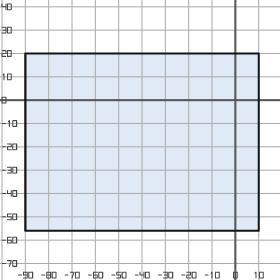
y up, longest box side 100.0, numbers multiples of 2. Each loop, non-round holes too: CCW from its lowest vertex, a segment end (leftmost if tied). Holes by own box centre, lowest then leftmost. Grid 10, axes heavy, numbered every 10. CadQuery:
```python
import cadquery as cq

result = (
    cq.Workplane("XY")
    .moveTo(-90.0, -56.0)
    .lineTo(10.0, -56.0)
    .lineTo(10.0, 20.0)
    .lineTo(-90.0, 20.0)
    .close()
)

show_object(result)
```